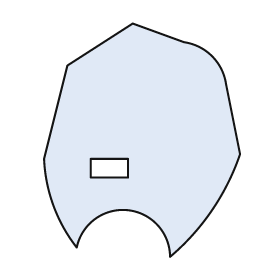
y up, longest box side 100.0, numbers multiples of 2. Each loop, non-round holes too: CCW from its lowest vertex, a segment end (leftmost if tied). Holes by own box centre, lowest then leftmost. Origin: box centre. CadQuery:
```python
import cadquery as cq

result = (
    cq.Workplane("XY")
    .moveTo(12.0, -50.0)
    .threePointArc((30.0, -30.0), (42.0, -6.0))
    .lineTo(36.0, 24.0)
    .threePointArc((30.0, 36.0), (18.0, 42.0))
    .lineTo(-4.0, 50.0)
    .lineTo(-32.0, 32.0)
    .lineTo(-42.0, -8.0)
    .threePointArc((-38.0, -28.0), (-28.0, -46.0))
    .threePointArc((-6.0, -30.0), (12.0, -50.0))
    .close()
    .moveTo(-22.0, -16.0)
    .lineTo(-6.0, -16.0)
    .lineTo(-6.0, -8.0)
    .lineTo(-22.0, -8.0)
    .close()
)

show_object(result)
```